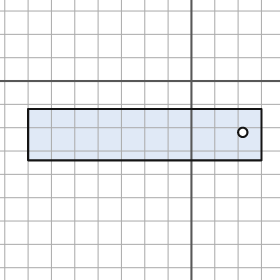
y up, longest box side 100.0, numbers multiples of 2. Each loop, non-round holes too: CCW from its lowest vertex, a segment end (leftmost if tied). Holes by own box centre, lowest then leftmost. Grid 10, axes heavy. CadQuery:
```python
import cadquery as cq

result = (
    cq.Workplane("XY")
    .moveTo(-70.0, -34.0)
    .lineTo(30.0, -34.0)
    .lineTo(30.0, -12.0)
    .lineTo(-70.0, -12.0)
    .close()
    .moveTo(22.0, -22.0)
    .circle(2.0)
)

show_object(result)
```